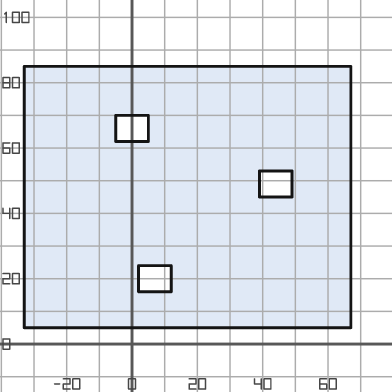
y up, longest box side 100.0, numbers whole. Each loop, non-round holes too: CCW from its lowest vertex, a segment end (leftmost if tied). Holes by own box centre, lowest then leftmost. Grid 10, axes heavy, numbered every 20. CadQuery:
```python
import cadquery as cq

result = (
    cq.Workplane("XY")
    .moveTo(-33.0, 5.0)
    .lineTo(67.0, 5.0)
    .lineTo(67.0, 85.0)
    .lineTo(-33.0, 85.0)
    .close()
    .moveTo(2.0, 16.0)
    .lineTo(12.0, 16.0)
    .lineTo(12.0, 24.0)
    .lineTo(2.0, 24.0)
    .close()
    .moveTo(39.0, 45.0)
    .lineTo(49.0, 45.0)
    .lineTo(49.0, 53.0)
    .lineTo(39.0, 53.0)
    .close()
    .moveTo(-5.0, 62.0)
    .lineTo(5.0, 62.0)
    .lineTo(5.0, 70.0)
    .lineTo(-5.0, 70.0)
    .close()
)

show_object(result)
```